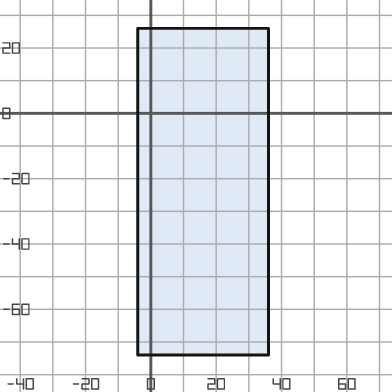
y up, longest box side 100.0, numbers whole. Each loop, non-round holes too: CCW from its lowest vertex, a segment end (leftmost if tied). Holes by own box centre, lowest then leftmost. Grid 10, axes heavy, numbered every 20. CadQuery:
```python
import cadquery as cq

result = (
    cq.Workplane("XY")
    .moveTo(-4.0, -74.0)
    .lineTo(36.0, -74.0)
    .lineTo(36.0, 26.0)
    .lineTo(-4.0, 26.0)
    .close()
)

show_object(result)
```